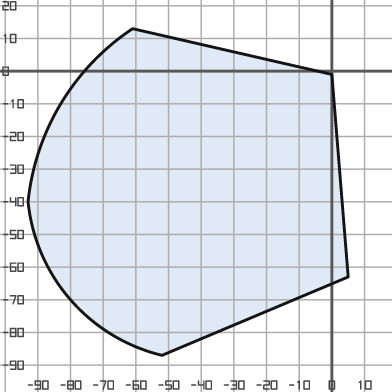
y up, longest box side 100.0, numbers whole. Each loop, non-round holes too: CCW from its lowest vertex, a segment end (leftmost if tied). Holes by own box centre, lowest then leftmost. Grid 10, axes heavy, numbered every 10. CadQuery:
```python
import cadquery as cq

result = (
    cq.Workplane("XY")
    .moveTo(-52.0, -87.0)
    .lineTo(5.0, -63.0)
    .lineTo(0.0, -1.0)
    .lineTo(-61.0, 13.0)
    .threePointArc((-83.0, -10.0), (-93.0, -40.0))
    .threePointArc((-80.0, -70.0), (-52.0, -87.0))
    .close()
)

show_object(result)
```